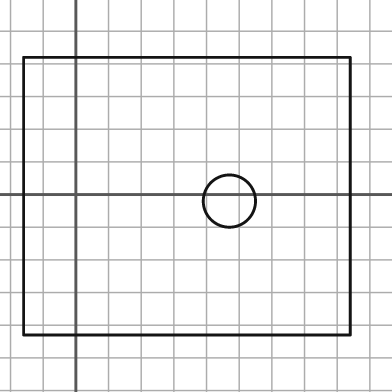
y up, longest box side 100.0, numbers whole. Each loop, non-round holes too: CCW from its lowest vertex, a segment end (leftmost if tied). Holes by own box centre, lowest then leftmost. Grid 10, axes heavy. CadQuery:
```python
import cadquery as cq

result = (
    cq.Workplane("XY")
    .moveTo(-16.0, -43.0)
    .lineTo(84.0, -43.0)
    .lineTo(84.0, 42.0)
    .lineTo(-16.0, 42.0)
    .close()
    .moveTo(47.0, -2.0)
    .circle(8.0)
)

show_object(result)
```